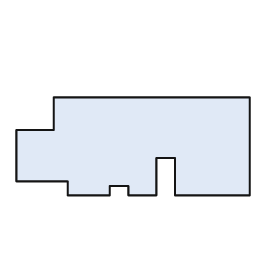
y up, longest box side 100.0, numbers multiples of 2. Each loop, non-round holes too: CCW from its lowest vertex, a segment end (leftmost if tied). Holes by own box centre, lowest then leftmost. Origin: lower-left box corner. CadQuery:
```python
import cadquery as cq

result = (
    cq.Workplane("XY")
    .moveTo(22.0, 0.0)
    .lineTo(40.0, 0.0)
    .lineTo(40.0, 4.0)
    .lineTo(48.0, 4.0)
    .lineTo(48.0, 0.0)
    .lineTo(60.0, 0.0)
    .lineTo(60.0, 16.0)
    .lineTo(68.0, 16.0)
    .lineTo(68.0, 0.0)
    .lineTo(100.0, 0.0)
    .lineTo(100.0, 42.0)
    .lineTo(16.0, 42.0)
    .lineTo(16.0, 28.0)
    .lineTo(0.0, 28.0)
    .lineTo(0.0, 6.0)
    .lineTo(22.0, 6.0)
    .close()
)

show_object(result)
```